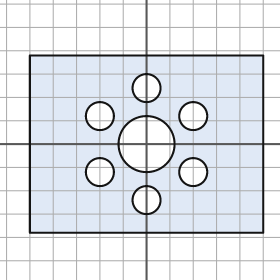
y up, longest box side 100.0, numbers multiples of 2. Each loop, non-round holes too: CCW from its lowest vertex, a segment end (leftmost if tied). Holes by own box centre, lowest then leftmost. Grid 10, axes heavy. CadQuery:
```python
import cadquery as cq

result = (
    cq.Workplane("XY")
    .moveTo(-50.0, -38.0)
    .lineTo(50.0, -38.0)
    .lineTo(50.0, 38.0)
    .lineTo(-50.0, 38.0)
    .close()
    .moveTo(0.0, -24.0)
    .circle(6.0)
    .moveTo(-20.0, -12.0)
    .circle(6.0)
    .moveTo(20.0, -12.0)
    .circle(6.0)
    .moveTo(0.0, 0.0)
    .circle(12.0)
    .moveTo(-20.0, 12.0)
    .circle(6.0)
    .moveTo(20.0, 12.0)
    .circle(6.0)
    .moveTo(0.0, 24.0)
    .circle(6.0)
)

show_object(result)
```